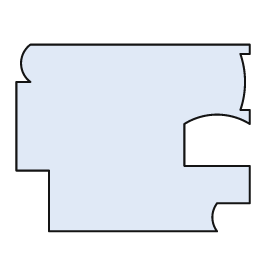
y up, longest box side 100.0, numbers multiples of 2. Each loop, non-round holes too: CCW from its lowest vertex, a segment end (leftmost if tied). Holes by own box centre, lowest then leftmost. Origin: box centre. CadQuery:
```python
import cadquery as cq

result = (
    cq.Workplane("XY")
    .moveTo(-36.0, -40.0)
    .lineTo(36.0, -40.0)
    .threePointArc((34.0, -34.0), (36.0, -28.0))
    .lineTo(50.0, -28.0)
    .lineTo(50.0, -12.0)
    .lineTo(22.0, -12.0)
    .lineTo(22.0, 6.0)
    .threePointArc((36.0, 10.0), (50.0, 6.0))
    .lineTo(50.0, 12.0)
    .lineTo(46.0, 12.0)
    .threePointArc((48.0, 24.0), (46.0, 36.0))
    .lineTo(50.0, 36.0)
    .lineTo(50.0, 40.0)
    .lineTo(-44.0, 40.0)
    .threePointArc((-48.0, 32.0), (-44.0, 24.0))
    .lineTo(-50.0, 24.0)
    .lineTo(-50.0, -14.0)
    .lineTo(-36.0, -14.0)
    .close()
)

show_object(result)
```